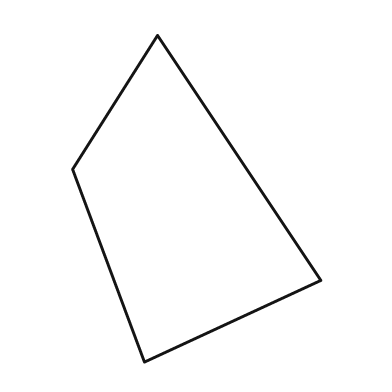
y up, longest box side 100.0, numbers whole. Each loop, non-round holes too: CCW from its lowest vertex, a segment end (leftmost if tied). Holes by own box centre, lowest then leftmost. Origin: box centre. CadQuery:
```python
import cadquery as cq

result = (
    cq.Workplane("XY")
    .moveTo(-16.0, -50.0)
    .lineTo(38.0, -25.0)
    .lineTo(-12.0, 50.0)
    .lineTo(-38.0, 9.0)
    .close()
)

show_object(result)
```